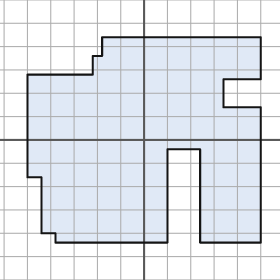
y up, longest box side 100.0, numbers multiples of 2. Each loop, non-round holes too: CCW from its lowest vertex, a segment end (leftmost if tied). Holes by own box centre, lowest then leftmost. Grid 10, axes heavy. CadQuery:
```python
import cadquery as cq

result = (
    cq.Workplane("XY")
    .moveTo(-38.0, -44.0)
    .lineTo(10.0, -44.0)
    .lineTo(10.0, -4.0)
    .lineTo(24.0, -4.0)
    .lineTo(24.0, -44.0)
    .lineTo(50.0, -44.0)
    .lineTo(50.0, 14.0)
    .lineTo(34.0, 14.0)
    .lineTo(34.0, 26.0)
    .lineTo(50.0, 26.0)
    .lineTo(50.0, 44.0)
    .lineTo(-18.0, 44.0)
    .lineTo(-18.0, 36.0)
    .lineTo(-22.0, 36.0)
    .lineTo(-22.0, 28.0)
    .lineTo(-50.0, 28.0)
    .lineTo(-50.0, -16.0)
    .lineTo(-44.0, -16.0)
    .lineTo(-44.0, -40.0)
    .lineTo(-38.0, -40.0)
    .close()
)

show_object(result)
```